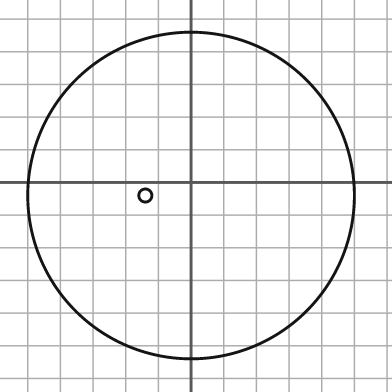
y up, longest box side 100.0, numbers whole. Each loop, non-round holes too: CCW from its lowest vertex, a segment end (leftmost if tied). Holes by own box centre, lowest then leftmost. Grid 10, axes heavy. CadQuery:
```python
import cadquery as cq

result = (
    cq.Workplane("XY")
    .moveTo(0.0, -4.0)
    .circle(50.0)
    .moveTo(-14.0, -4.0)
    .circle(2.0)
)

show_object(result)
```